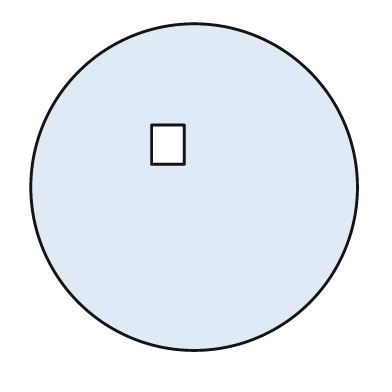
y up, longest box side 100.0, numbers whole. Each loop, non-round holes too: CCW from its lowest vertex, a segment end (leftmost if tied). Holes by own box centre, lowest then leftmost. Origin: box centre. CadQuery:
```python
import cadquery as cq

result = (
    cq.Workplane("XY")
    .moveTo(0.0, 0.0)
    .circle(50.0)
    .moveTo(-13.0, 7.0)
    .lineTo(-3.0, 7.0)
    .lineTo(-3.0, 19.0)
    .lineTo(-13.0, 19.0)
    .close()
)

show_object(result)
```